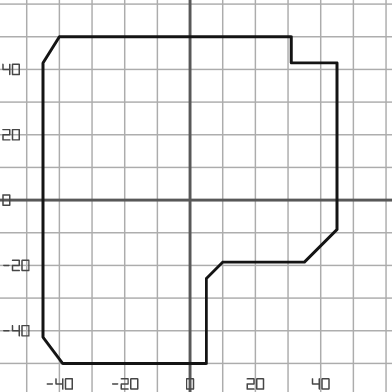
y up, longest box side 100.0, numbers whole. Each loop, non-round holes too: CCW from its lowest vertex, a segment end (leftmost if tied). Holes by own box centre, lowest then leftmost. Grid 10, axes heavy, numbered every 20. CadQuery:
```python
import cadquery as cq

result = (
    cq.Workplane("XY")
    .moveTo(-39.0, -50.0)
    .lineTo(5.0, -50.0)
    .lineTo(5.0, -24.0)
    .lineTo(10.0, -19.0)
    .lineTo(35.0, -19.0)
    .lineTo(45.0, -9.0)
    .lineTo(45.0, 42.0)
    .lineTo(31.0, 42.0)
    .lineTo(31.0, 50.0)
    .lineTo(-40.0, 50.0)
    .lineTo(-45.0, 42.0)
    .lineTo(-45.0, -42.0)
    .close()
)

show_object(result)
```